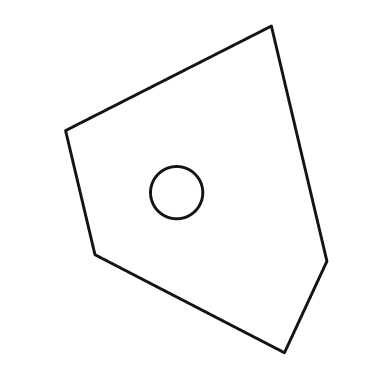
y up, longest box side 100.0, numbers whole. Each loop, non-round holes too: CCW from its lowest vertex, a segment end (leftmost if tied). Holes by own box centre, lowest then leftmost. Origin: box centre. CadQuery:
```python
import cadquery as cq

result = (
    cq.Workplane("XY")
    .moveTo(27.0, -50.0)
    .lineTo(40.0, -22.0)
    .lineTo(23.0, 50.0)
    .lineTo(-40.0, 18.0)
    .lineTo(-31.0, -20.0)
    .close()
    .moveTo(-6.0, -1.0)
    .circle(8.0)
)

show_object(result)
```